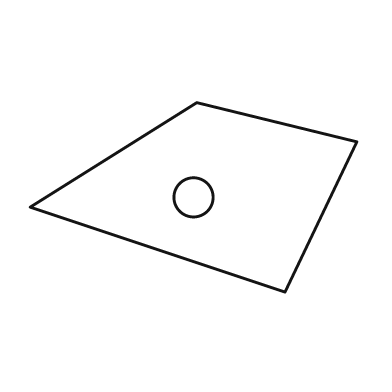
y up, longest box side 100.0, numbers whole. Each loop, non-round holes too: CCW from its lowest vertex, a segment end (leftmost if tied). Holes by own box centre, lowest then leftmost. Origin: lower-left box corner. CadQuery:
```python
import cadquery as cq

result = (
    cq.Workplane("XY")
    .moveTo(78.0, 0.0)
    .lineTo(100.0, 46.0)
    .lineTo(51.0, 58.0)
    .lineTo(0.0, 26.0)
    .close()
    .moveTo(50.0, 29.0)
    .circle(6.0)
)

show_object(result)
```